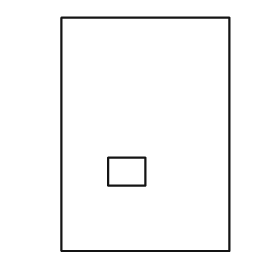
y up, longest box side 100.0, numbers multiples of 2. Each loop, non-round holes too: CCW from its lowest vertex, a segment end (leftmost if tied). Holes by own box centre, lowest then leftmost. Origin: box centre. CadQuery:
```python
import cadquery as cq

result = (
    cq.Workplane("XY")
    .moveTo(-36.0, -50.0)
    .lineTo(36.0, -50.0)
    .lineTo(36.0, 50.0)
    .lineTo(-36.0, 50.0)
    .close()
    .moveTo(-16.0, -22.0)
    .lineTo(0.0, -22.0)
    .lineTo(0.0, -10.0)
    .lineTo(-16.0, -10.0)
    .close()
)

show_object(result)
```